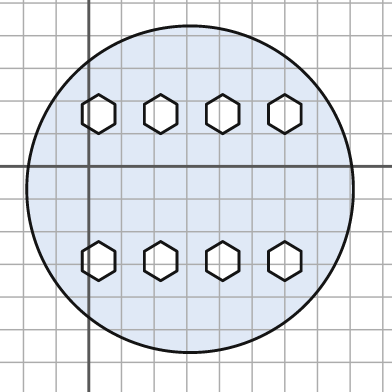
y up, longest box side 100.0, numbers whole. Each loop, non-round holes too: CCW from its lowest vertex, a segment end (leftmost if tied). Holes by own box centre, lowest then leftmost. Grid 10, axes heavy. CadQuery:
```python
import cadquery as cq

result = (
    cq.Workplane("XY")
    .moveTo(31.0, -7.0)
    .circle(50.0)
    .moveTo(3.0, -35.0)
    .lineTo(8.0, -32.0)
    .lineTo(8.0, -26.0)
    .lineTo(3.0, -23.0)
    .lineTo(-2.0, -26.0)
    .lineTo(-2.0, -32.0)
    .close()
    .moveTo(22.0, -35.0)
    .lineTo(27.0, -32.0)
    .lineTo(27.0, -26.0)
    .lineTo(22.0, -23.0)
    .lineTo(17.0, -26.0)
    .lineTo(17.0, -32.0)
    .close()
    .moveTo(41.0, -35.0)
    .lineTo(46.0, -32.0)
    .lineTo(46.0, -26.0)
    .lineTo(41.0, -23.0)
    .lineTo(36.0, -26.0)
    .lineTo(36.0, -32.0)
    .close()
    .moveTo(60.0, -35.0)
    .lineTo(65.0, -32.0)
    .lineTo(65.0, -26.0)
    .lineTo(60.0, -23.0)
    .lineTo(55.0, -26.0)
    .lineTo(55.0, -32.0)
    .close()
    .moveTo(3.0, 10.0)
    .lineTo(8.0, 13.0)
    .lineTo(8.0, 19.0)
    .lineTo(3.0, 22.0)
    .lineTo(-2.0, 19.0)
    .lineTo(-2.0, 13.0)
    .close()
    .moveTo(22.0, 10.0)
    .lineTo(27.0, 13.0)
    .lineTo(27.0, 19.0)
    .lineTo(22.0, 22.0)
    .lineTo(17.0, 19.0)
    .lineTo(17.0, 13.0)
    .close()
    .moveTo(41.0, 10.0)
    .lineTo(46.0, 13.0)
    .lineTo(46.0, 19.0)
    .lineTo(41.0, 22.0)
    .lineTo(36.0, 19.0)
    .lineTo(36.0, 13.0)
    .close()
    .moveTo(60.0, 10.0)
    .lineTo(65.0, 13.0)
    .lineTo(65.0, 19.0)
    .lineTo(60.0, 22.0)
    .lineTo(55.0, 19.0)
    .lineTo(55.0, 13.0)
    .close()
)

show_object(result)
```